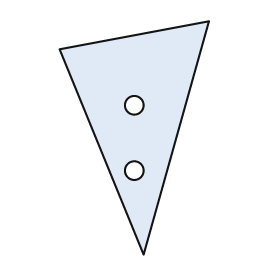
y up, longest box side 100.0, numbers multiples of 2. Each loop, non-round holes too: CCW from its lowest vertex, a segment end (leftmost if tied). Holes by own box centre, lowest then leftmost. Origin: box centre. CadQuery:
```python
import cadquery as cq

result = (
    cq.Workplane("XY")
    .moveTo(4.0, -50.0)
    .lineTo(32.0, 50.0)
    .lineTo(-32.0, 38.0)
    .close()
    .moveTo(0.0, -14.0)
    .circle(4.0)
    .moveTo(0.0, 14.0)
    .circle(4.0)
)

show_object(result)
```